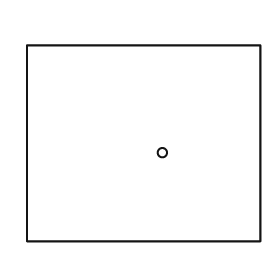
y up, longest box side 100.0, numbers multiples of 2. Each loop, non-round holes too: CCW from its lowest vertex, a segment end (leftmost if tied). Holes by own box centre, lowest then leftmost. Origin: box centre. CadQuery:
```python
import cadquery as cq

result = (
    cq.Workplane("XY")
    .moveTo(-50.0, -42.0)
    .lineTo(50.0, -42.0)
    .lineTo(50.0, 42.0)
    .lineTo(-50.0, 42.0)
    .close()
    .moveTo(8.0, -4.0)
    .circle(2.0)
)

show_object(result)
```